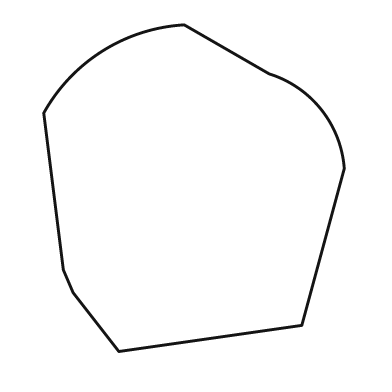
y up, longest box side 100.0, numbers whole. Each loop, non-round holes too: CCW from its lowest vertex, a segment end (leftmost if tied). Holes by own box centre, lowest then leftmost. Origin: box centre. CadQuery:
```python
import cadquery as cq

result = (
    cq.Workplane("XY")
    .moveTo(-23.0, -50.0)
    .lineTo(33.0, -42.0)
    .lineTo(46.0, 6.0)
    .threePointArc((39.0, 24.0), (23.0, 35.0))
    .lineTo(-3.0, 50.0)
    .threePointArc((-28.0, 42.0), (-46.0, 23.0))
    .lineTo(-40.0, -25.0)
    .lineTo(-37.0, -32.0)
    .close()
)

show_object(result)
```